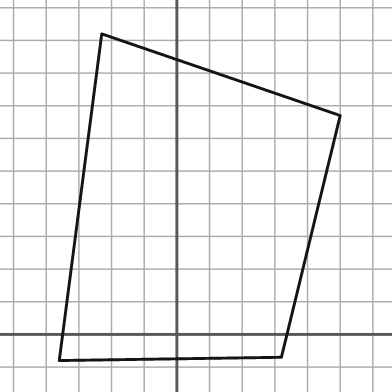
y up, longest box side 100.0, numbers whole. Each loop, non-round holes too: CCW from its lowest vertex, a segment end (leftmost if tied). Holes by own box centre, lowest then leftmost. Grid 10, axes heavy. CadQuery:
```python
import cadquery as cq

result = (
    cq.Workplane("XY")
    .moveTo(-36.0, -8.0)
    .lineTo(32.0, -7.0)
    .lineTo(50.0, 67.0)
    .lineTo(-23.0, 92.0)
    .close()
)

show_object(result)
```